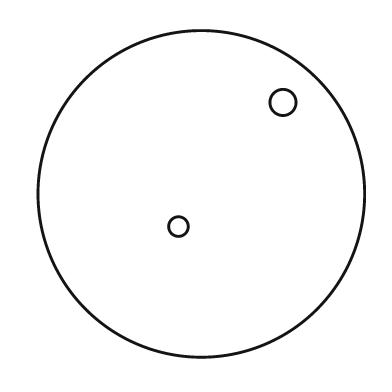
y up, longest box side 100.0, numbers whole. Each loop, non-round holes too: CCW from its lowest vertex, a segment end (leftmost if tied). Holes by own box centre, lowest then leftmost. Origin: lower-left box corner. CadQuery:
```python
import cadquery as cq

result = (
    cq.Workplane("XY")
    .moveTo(50.0, 50.0)
    .circle(50.0)
    .moveTo(43.0, 40.0)
    .circle(3.0)
    .moveTo(75.0, 78.0)
    .circle(4.0)
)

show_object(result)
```